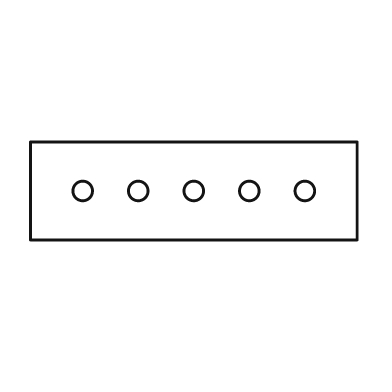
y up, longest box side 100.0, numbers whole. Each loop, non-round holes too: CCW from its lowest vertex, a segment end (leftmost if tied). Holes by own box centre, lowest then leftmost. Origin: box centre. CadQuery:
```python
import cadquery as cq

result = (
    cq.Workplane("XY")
    .moveTo(-50.0, -15.0)
    .lineTo(50.0, -15.0)
    .lineTo(50.0, 15.0)
    .lineTo(-50.0, 15.0)
    .close()
    .moveTo(-34.0, 0.0)
    .circle(3.0)
    .moveTo(-17.0, 0.0)
    .circle(3.0)
    .moveTo(0.0, 0.0)
    .circle(3.0)
    .moveTo(17.0, 0.0)
    .circle(3.0)
    .moveTo(34.0, 0.0)
    .circle(3.0)
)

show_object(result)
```